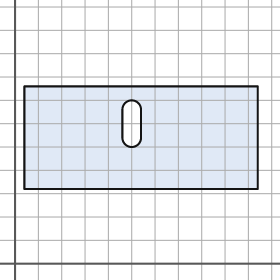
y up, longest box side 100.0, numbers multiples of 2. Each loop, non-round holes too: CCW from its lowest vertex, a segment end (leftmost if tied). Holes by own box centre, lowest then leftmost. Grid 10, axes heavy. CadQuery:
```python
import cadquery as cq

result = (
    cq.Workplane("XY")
    .moveTo(4.0, 32.0)
    .lineTo(104.0, 32.0)
    .lineTo(104.0, 76.0)
    .lineTo(4.0, 76.0)
    .close()
    .moveTo(46.0, 54.0)
    .threePointArc((50.0, 50.0), (54.0, 54.0))
    .lineTo(54.0, 66.0)
    .threePointArc((50.0, 70.0), (46.0, 66.0))
    .close()
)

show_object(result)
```